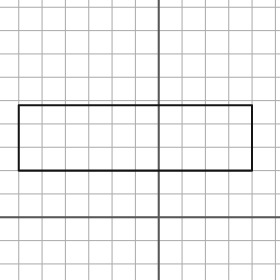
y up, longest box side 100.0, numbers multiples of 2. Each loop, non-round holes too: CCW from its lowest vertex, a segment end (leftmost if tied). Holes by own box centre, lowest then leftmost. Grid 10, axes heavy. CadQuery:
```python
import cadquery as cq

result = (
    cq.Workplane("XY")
    .moveTo(-60.0, 20.0)
    .lineTo(40.0, 20.0)
    .lineTo(40.0, 48.0)
    .lineTo(-60.0, 48.0)
    .close()
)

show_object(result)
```